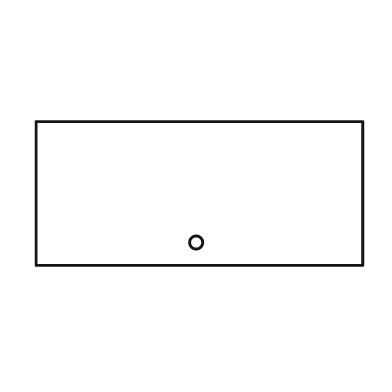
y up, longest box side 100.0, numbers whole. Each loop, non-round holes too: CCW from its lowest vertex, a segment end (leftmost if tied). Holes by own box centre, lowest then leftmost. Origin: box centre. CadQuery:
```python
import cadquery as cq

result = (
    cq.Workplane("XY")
    .moveTo(-50.0, -22.0)
    .lineTo(50.0, -22.0)
    .lineTo(50.0, 22.0)
    .lineTo(-50.0, 22.0)
    .close()
    .moveTo(-1.0, -15.0)
    .circle(2.0)
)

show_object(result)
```